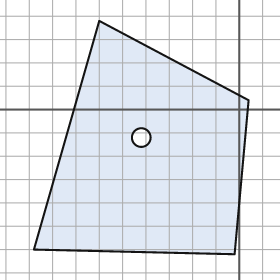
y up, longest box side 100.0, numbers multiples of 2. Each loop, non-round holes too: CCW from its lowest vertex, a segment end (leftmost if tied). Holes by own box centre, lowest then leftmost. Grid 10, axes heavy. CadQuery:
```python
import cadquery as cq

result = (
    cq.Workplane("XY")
    .moveTo(-2.0, -62.0)
    .lineTo(4.0, 4.0)
    .lineTo(-60.0, 38.0)
    .lineTo(-88.0, -60.0)
    .close()
    .moveTo(-42.0, -12.0)
    .circle(4.0)
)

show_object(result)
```